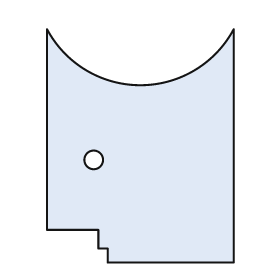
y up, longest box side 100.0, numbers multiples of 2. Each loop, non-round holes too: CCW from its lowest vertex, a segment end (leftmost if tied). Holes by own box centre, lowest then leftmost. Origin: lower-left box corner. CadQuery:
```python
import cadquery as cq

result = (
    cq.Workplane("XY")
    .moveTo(26.0, 0.0)
    .lineTo(80.0, 0.0)
    .lineTo(80.0, 100.0)
    .threePointArc((40.0, 76.0), (0.0, 100.0))
    .lineTo(0.0, 14.0)
    .lineTo(22.0, 14.0)
    .lineTo(22.0, 6.0)
    .lineTo(26.0, 6.0)
    .close()
    .moveTo(20.0, 44.0)
    .circle(4.0)
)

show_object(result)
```